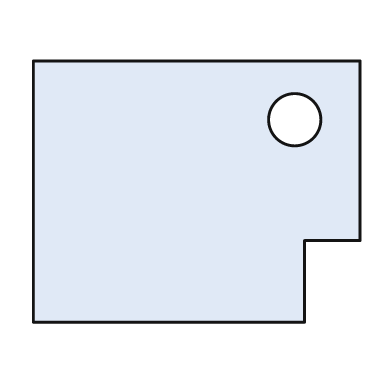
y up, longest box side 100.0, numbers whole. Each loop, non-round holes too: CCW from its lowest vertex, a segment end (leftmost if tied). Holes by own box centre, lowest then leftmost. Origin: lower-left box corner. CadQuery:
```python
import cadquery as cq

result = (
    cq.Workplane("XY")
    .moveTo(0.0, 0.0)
    .lineTo(83.0, 0.0)
    .lineTo(83.0, 25.0)
    .lineTo(100.0, 25.0)
    .lineTo(100.0, 80.0)
    .lineTo(0.0, 80.0)
    .close()
    .moveTo(80.0, 62.0)
    .circle(8.0)
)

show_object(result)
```